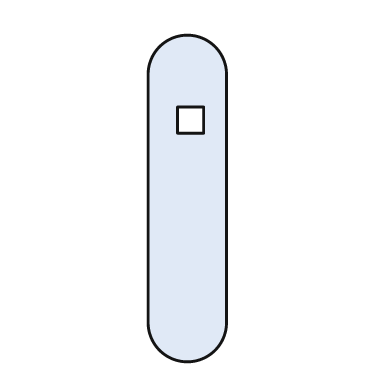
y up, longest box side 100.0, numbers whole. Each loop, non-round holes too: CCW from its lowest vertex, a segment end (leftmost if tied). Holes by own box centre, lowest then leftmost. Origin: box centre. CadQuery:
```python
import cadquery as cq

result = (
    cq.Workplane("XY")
    .moveTo(-12.0, -38.0)
    .threePointArc((0.0, -50.0), (12.0, -38.0))
    .lineTo(12.0, 38.0)
    .threePointArc((0.0, 50.0), (-12.0, 38.0))
    .close()
    .moveTo(-3.0, 20.0)
    .lineTo(5.0, 20.0)
    .lineTo(5.0, 28.0)
    .lineTo(-3.0, 28.0)
    .close()
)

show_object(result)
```